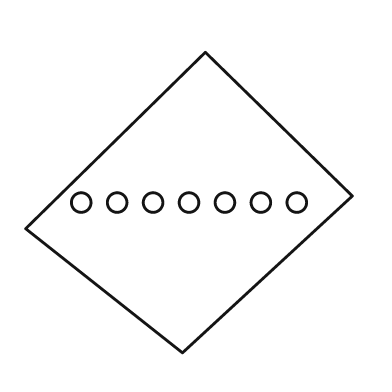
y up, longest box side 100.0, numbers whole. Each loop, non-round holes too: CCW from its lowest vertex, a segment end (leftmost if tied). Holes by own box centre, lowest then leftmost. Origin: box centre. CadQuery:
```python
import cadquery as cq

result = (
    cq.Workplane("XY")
    .moveTo(-2.0, -46.0)
    .lineTo(50.0, 2.0)
    .lineTo(5.0, 46.0)
    .lineTo(-50.0, -8.0)
    .close()
    .moveTo(-33.0, 0.0)
    .circle(3.0)
    .moveTo(-22.0, 0.0)
    .circle(3.0)
    .moveTo(-11.0, 0.0)
    .circle(3.0)
    .moveTo(0.0, 0.0)
    .circle(3.0)
    .moveTo(11.0, 0.0)
    .circle(3.0)
    .moveTo(22.0, 0.0)
    .circle(3.0)
    .moveTo(33.0, 0.0)
    .circle(3.0)
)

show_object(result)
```